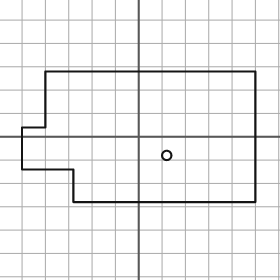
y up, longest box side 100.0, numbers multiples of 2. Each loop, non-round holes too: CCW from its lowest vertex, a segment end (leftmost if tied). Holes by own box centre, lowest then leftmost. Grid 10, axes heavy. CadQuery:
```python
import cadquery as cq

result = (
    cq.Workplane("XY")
    .moveTo(-28.0, -28.0)
    .lineTo(50.0, -28.0)
    .lineTo(50.0, 28.0)
    .lineTo(-40.0, 28.0)
    .lineTo(-40.0, 4.0)
    .lineTo(-50.0, 4.0)
    .lineTo(-50.0, -14.0)
    .lineTo(-28.0, -14.0)
    .close()
    .moveTo(12.0, -8.0)
    .circle(2.0)
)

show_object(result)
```